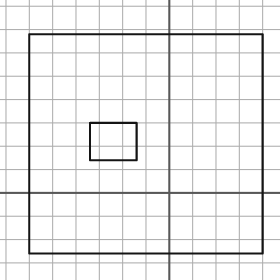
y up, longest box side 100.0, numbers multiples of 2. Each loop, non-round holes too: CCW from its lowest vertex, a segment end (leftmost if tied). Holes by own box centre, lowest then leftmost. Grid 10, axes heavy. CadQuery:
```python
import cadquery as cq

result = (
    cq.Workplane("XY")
    .moveTo(-60.0, -26.0)
    .lineTo(40.0, -26.0)
    .lineTo(40.0, 68.0)
    .lineTo(-60.0, 68.0)
    .close()
    .moveTo(-34.0, 14.0)
    .lineTo(-14.0, 14.0)
    .lineTo(-14.0, 30.0)
    .lineTo(-34.0, 30.0)
    .close()
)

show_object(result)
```